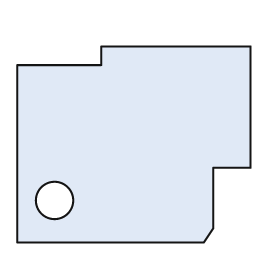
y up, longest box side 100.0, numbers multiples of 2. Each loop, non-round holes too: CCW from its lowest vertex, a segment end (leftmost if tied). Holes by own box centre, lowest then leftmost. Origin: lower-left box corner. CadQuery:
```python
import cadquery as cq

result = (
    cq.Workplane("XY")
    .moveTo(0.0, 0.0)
    .lineTo(80.0, 0.0)
    .lineTo(84.0, 6.0)
    .lineTo(84.0, 32.0)
    .lineTo(100.0, 32.0)
    .lineTo(100.0, 84.0)
    .lineTo(36.0, 84.0)
    .lineTo(36.0, 76.0)
    .lineTo(0.0, 76.0)
    .close()
    .moveTo(16.0, 18.0)
    .circle(8.0)
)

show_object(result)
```